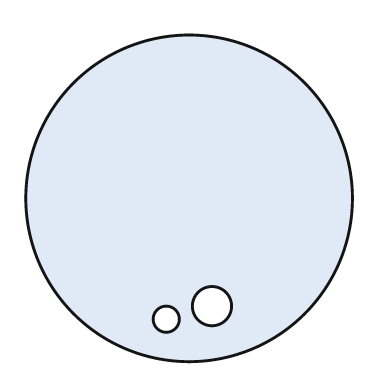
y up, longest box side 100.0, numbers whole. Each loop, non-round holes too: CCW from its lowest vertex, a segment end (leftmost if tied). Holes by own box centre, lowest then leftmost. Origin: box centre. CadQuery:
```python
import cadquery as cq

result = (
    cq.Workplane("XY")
    .moveTo(0.0, 0.0)
    .circle(50.0)
    .moveTo(-7.0, -37.0)
    .circle(4.0)
    .moveTo(7.0, -33.0)
    .circle(6.0)
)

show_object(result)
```